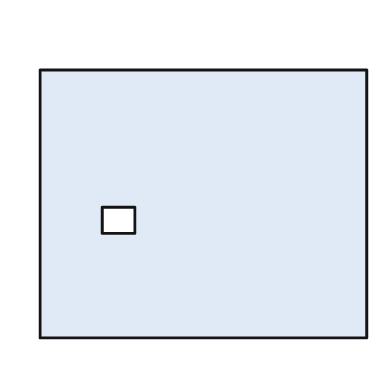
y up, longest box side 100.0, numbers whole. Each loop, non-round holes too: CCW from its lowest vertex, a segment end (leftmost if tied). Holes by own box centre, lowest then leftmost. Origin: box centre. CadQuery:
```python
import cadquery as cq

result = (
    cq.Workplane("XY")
    .moveTo(-50.0, -41.0)
    .lineTo(50.0, -41.0)
    .lineTo(50.0, 41.0)
    .lineTo(-50.0, 41.0)
    .close()
    .moveTo(-31.0, -9.0)
    .lineTo(-21.0, -9.0)
    .lineTo(-21.0, -1.0)
    .lineTo(-31.0, -1.0)
    .close()
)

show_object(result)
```